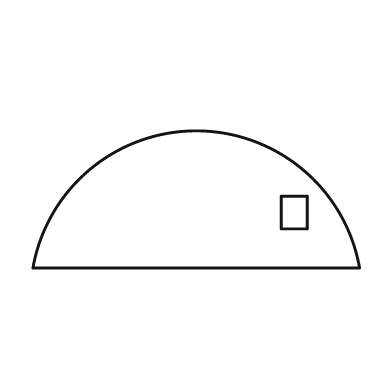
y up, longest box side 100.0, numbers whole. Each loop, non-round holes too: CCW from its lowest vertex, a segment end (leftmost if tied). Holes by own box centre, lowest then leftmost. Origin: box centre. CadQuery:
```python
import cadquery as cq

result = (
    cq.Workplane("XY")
    .moveTo(-50.0, -21.0)
    .lineTo(50.0, -21.0)
    .threePointArc((0.0, 21.0), (-50.0, -21.0))
    .close()
    .moveTo(26.0, -9.0)
    .lineTo(34.0, -9.0)
    .lineTo(34.0, 1.0)
    .lineTo(26.0, 1.0)
    .close()
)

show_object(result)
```